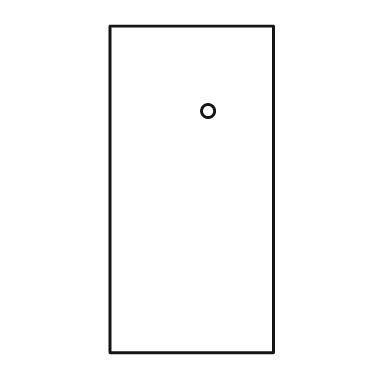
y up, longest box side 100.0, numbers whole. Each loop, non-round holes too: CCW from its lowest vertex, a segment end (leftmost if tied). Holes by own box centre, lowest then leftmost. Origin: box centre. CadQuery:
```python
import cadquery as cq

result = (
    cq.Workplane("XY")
    .moveTo(-25.0, -50.0)
    .lineTo(25.0, -50.0)
    .lineTo(25.0, 50.0)
    .lineTo(-25.0, 50.0)
    .close()
    .moveTo(5.0, 24.0)
    .circle(2.0)
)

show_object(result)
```